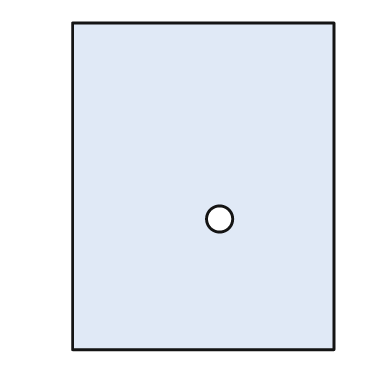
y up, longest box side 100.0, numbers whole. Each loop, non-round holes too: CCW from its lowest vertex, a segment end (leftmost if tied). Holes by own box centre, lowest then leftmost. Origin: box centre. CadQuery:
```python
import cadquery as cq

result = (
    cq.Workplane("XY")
    .moveTo(-40.0, -50.0)
    .lineTo(40.0, -50.0)
    .lineTo(40.0, 50.0)
    .lineTo(-40.0, 50.0)
    .close()
    .moveTo(5.0, -10.0)
    .circle(4.0)
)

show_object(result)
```